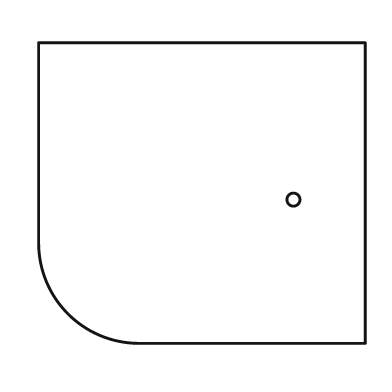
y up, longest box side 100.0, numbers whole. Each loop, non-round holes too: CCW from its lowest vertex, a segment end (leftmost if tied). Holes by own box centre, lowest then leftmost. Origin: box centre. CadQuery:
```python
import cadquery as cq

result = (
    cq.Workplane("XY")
    .moveTo(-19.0, -46.0)
    .lineTo(50.0, -46.0)
    .lineTo(50.0, 46.0)
    .lineTo(-50.0, 46.0)
    .lineTo(-50.0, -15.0)
    .threePointArc((-41.0, -37.0), (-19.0, -46.0))
    .close()
    .moveTo(28.0, -2.0)
    .circle(2.0)
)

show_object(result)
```